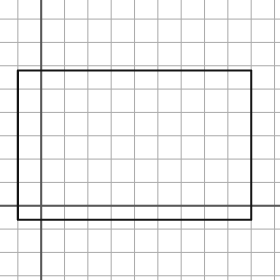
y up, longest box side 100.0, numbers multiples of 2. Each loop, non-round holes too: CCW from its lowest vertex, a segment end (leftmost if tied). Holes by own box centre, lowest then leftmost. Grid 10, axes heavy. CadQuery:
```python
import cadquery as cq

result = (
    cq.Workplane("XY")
    .moveTo(-10.0, -6.0)
    .lineTo(90.0, -6.0)
    .lineTo(90.0, 58.0)
    .lineTo(-10.0, 58.0)
    .close()
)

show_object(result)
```